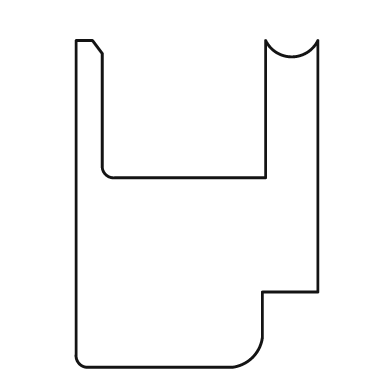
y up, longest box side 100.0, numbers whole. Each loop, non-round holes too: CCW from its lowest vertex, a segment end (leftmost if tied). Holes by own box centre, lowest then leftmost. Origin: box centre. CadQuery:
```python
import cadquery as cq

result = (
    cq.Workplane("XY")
    .moveTo(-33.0, -50.0)
    .lineTo(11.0, -50.0)
    .threePointArc((17.0, -47.0), (20.0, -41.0))
    .lineTo(20.0, -27.0)
    .lineTo(37.0, -27.0)
    .lineTo(37.0, 50.0)
    .threePointArc((29.0, 45.0), (21.0, 50.0))
    .lineTo(21.0, 8.0)
    .lineTo(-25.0, 8.0)
    .threePointArc((-28.0, 9.0), (-29.0, 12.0))
    .lineTo(-29.0, 46.0)
    .lineTo(-32.0, 50.0)
    .lineTo(-37.0, 50.0)
    .lineTo(-37.0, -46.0)
    .threePointArc((-36.0, -49.0), (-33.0, -50.0))
    .close()
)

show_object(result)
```